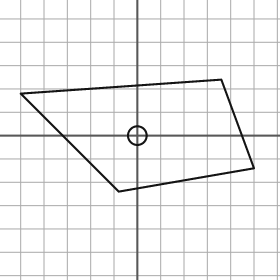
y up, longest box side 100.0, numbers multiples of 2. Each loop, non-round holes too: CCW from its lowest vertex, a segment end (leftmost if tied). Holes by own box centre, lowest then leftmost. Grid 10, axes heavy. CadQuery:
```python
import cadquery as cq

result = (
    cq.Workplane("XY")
    .moveTo(-8.0, -24.0)
    .lineTo(50.0, -14.0)
    .lineTo(36.0, 24.0)
    .lineTo(-50.0, 18.0)
    .close()
    .moveTo(0.0, 0.0)
    .circle(4.0)
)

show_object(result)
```